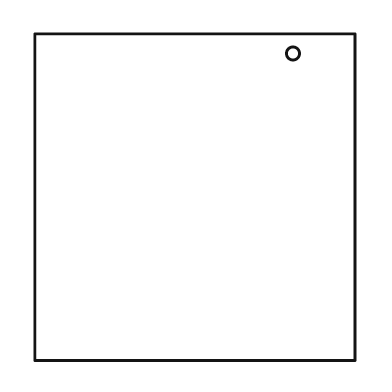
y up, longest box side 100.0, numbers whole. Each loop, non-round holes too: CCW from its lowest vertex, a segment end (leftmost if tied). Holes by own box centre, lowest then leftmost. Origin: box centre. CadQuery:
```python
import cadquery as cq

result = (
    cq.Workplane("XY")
    .moveTo(-49.0, -50.0)
    .lineTo(49.0, -50.0)
    .lineTo(49.0, 50.0)
    .lineTo(-49.0, 50.0)
    .close()
    .moveTo(30.0, 44.0)
    .circle(2.0)
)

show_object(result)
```